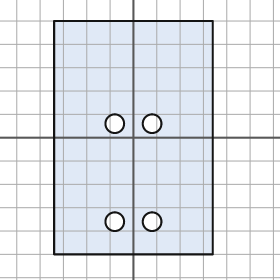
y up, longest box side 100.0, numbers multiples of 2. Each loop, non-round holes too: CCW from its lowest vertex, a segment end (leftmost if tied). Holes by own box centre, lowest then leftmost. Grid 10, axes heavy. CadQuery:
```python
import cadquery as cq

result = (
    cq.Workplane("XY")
    .moveTo(-34.0, -50.0)
    .lineTo(34.0, -50.0)
    .lineTo(34.0, 50.0)
    .lineTo(-34.0, 50.0)
    .close()
    .moveTo(-8.0, -36.0)
    .circle(4.0)
    .moveTo(8.0, -36.0)
    .circle(4.0)
    .moveTo(-8.0, 6.0)
    .circle(4.0)
    .moveTo(8.0, 6.0)
    .circle(4.0)
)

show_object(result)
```